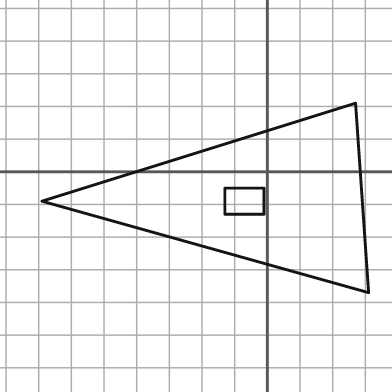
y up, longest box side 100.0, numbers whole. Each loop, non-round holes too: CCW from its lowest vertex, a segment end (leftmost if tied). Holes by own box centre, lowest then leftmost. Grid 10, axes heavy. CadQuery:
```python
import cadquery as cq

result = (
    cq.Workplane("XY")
    .moveTo(31.0, -37.0)
    .lineTo(27.0, 21.0)
    .lineTo(-69.0, -9.0)
    .close()
    .moveTo(-13.0, -13.0)
    .lineTo(-1.0, -13.0)
    .lineTo(-1.0, -5.0)
    .lineTo(-13.0, -5.0)
    .close()
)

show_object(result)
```